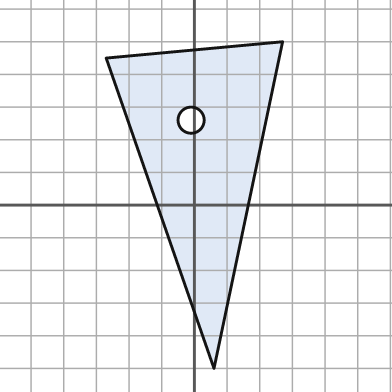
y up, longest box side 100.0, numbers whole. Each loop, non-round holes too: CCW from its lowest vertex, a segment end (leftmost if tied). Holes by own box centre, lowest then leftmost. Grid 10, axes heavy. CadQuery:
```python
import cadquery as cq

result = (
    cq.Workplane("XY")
    .moveTo(6.0, -50.0)
    .lineTo(27.0, 50.0)
    .lineTo(-27.0, 45.0)
    .close()
    .moveTo(-1.0, 26.0)
    .circle(4.0)
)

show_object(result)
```